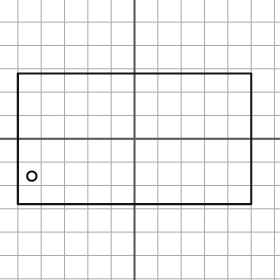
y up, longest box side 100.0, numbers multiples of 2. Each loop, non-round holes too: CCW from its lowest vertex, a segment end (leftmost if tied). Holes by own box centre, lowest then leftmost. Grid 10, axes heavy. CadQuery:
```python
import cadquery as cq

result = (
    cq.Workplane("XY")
    .moveTo(-50.0, -28.0)
    .lineTo(50.0, -28.0)
    .lineTo(50.0, 28.0)
    .lineTo(-50.0, 28.0)
    .close()
    .moveTo(-44.0, -16.0)
    .circle(2.0)
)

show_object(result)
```